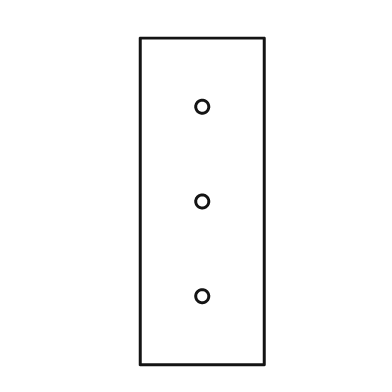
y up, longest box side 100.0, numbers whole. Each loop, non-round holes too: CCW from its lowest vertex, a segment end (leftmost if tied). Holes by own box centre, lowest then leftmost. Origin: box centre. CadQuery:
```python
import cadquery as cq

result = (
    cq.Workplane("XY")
    .moveTo(-19.0, -50.0)
    .lineTo(19.0, -50.0)
    .lineTo(19.0, 50.0)
    .lineTo(-19.0, 50.0)
    .close()
    .moveTo(0.0, -29.0)
    .circle(2.0)
    .moveTo(0.0, 0.0)
    .circle(2.0)
    .moveTo(0.0, 29.0)
    .circle(2.0)
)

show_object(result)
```